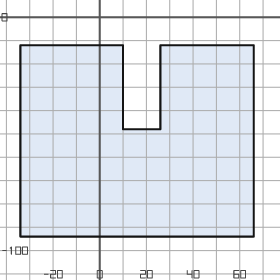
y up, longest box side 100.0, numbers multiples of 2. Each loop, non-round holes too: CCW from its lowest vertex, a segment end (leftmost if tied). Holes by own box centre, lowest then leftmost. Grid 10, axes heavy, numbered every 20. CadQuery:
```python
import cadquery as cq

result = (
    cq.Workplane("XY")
    .moveTo(-34.0, -94.0)
    .lineTo(66.0, -94.0)
    .lineTo(66.0, -12.0)
    .lineTo(26.0, -12.0)
    .lineTo(26.0, -48.0)
    .lineTo(10.0, -48.0)
    .lineTo(10.0, -12.0)
    .lineTo(-34.0, -12.0)
    .close()
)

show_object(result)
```